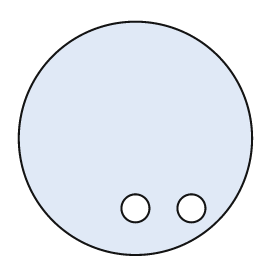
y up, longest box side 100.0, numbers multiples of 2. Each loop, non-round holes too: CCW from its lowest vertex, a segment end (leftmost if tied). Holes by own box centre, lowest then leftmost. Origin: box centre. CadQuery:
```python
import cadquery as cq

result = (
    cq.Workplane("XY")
    .moveTo(0.0, 0.0)
    .circle(50.0)
    .moveTo(0.0, -30.0)
    .circle(6.0)
    .moveTo(24.0, -30.0)
    .circle(6.0)
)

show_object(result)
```